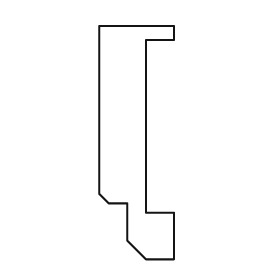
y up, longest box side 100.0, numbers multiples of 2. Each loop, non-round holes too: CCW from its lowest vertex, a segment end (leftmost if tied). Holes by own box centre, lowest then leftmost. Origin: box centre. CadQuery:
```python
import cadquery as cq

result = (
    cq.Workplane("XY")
    .moveTo(4.0, -50.0)
    .lineTo(16.0, -50.0)
    .lineTo(16.0, -30.0)
    .lineTo(4.0, -30.0)
    .lineTo(4.0, 44.0)
    .lineTo(16.0, 44.0)
    .lineTo(16.0, 50.0)
    .lineTo(-16.0, 50.0)
    .lineTo(-16.0, -22.0)
    .lineTo(-12.0, -26.0)
    .lineTo(-4.0, -26.0)
    .lineTo(-4.0, -42.0)
    .close()
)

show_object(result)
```